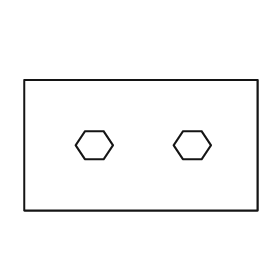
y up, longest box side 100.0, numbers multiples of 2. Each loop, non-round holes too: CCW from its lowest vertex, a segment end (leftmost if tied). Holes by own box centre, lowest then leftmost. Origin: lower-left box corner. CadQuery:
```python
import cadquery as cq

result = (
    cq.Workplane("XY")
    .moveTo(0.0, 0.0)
    .lineTo(100.0, 0.0)
    .lineTo(100.0, 56.0)
    .lineTo(0.0, 56.0)
    .close()
    .moveTo(26.0, 22.0)
    .lineTo(34.0, 22.0)
    .lineTo(38.0, 28.0)
    .lineTo(34.0, 34.0)
    .lineTo(26.0, 34.0)
    .lineTo(22.0, 28.0)
    .close()
    .moveTo(68.0, 22.0)
    .lineTo(76.0, 22.0)
    .lineTo(80.0, 28.0)
    .lineTo(76.0, 34.0)
    .lineTo(68.0, 34.0)
    .lineTo(64.0, 28.0)
    .close()
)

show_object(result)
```